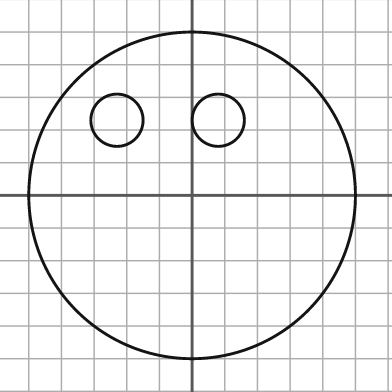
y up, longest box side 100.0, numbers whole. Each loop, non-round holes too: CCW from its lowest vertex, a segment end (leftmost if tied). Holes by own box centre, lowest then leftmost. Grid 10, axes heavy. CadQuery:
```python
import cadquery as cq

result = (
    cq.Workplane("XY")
    .moveTo(0.0, 0.0)
    .circle(50.0)
    .moveTo(-23.0, 23.0)
    .circle(8.0)
    .moveTo(8.0, 23.0)
    .circle(8.0)
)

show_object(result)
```